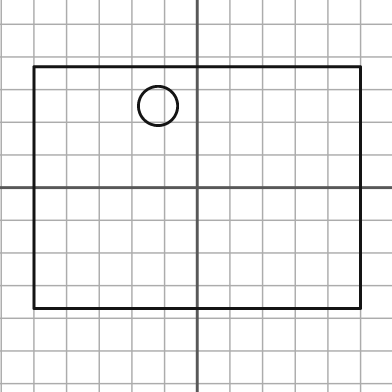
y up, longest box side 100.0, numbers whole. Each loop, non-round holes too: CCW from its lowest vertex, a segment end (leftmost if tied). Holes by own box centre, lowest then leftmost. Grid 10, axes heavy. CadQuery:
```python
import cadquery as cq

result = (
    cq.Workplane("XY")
    .moveTo(-50.0, -37.0)
    .lineTo(50.0, -37.0)
    .lineTo(50.0, 37.0)
    .lineTo(-50.0, 37.0)
    .close()
    .moveTo(-12.0, 25.0)
    .circle(6.0)
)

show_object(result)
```